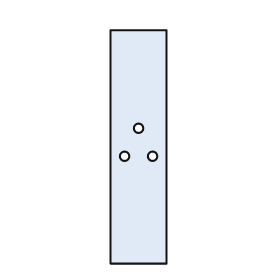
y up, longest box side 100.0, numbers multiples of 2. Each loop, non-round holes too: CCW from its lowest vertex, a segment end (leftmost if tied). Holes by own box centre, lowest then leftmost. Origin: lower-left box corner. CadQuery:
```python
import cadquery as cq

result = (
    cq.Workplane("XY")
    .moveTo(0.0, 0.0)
    .lineTo(24.0, 0.0)
    .lineTo(24.0, 100.0)
    .lineTo(0.0, 100.0)
    .close()
    .moveTo(6.0, 46.0)
    .circle(2.0)
    .moveTo(18.0, 46.0)
    .circle(2.0)
    .moveTo(12.0, 58.0)
    .circle(2.0)
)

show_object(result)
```